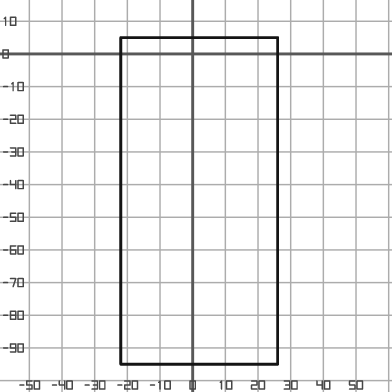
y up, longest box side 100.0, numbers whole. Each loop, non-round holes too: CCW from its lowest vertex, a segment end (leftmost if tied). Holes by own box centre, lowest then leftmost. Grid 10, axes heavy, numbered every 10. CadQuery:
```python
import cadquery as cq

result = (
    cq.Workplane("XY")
    .moveTo(-22.0, -95.0)
    .lineTo(26.0, -95.0)
    .lineTo(26.0, 5.0)
    .lineTo(-22.0, 5.0)
    .close()
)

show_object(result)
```